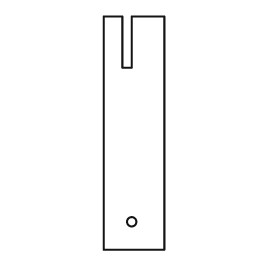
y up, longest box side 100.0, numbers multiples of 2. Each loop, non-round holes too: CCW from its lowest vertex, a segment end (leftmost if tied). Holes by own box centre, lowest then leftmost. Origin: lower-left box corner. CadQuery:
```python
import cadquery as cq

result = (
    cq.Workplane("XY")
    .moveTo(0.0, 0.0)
    .lineTo(26.0, 0.0)
    .lineTo(26.0, 100.0)
    .lineTo(12.0, 100.0)
    .lineTo(12.0, 78.0)
    .lineTo(8.0, 78.0)
    .lineTo(8.0, 100.0)
    .lineTo(0.0, 100.0)
    .close()
    .moveTo(12.0, 12.0)
    .circle(2.0)
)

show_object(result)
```